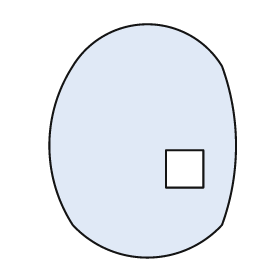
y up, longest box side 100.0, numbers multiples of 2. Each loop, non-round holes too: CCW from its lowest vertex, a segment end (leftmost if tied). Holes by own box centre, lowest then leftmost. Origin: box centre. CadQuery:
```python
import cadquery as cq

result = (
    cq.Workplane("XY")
    .moveTo(-30.0, -36.0)
    .threePointArc((2.0, -50.0), (34.0, -36.0))
    .threePointArc((40.0, -2.0), (34.0, 32.0))
    .threePointArc((2.0, 50.0), (-30.0, 32.0))
    .threePointArc((-40.0, -2.0), (-30.0, -36.0))
    .close()
    .moveTo(10.0, -20.0)
    .lineTo(26.0, -20.0)
    .lineTo(26.0, -4.0)
    .lineTo(10.0, -4.0)
    .close()
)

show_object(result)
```